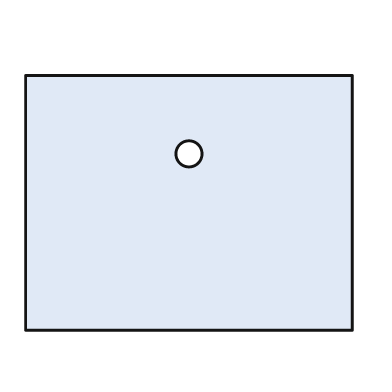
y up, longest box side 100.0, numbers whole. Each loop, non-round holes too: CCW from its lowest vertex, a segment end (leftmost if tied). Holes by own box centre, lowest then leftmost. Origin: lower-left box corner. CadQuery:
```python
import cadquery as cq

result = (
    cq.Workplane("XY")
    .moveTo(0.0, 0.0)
    .lineTo(100.0, 0.0)
    .lineTo(100.0, 78.0)
    .lineTo(0.0, 78.0)
    .close()
    .moveTo(50.0, 54.0)
    .circle(4.0)
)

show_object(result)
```